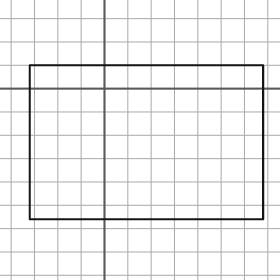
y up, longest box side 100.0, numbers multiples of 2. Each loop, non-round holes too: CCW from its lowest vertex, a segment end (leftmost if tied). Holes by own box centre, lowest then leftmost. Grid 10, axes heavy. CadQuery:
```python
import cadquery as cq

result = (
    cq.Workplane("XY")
    .moveTo(-32.0, -56.0)
    .lineTo(68.0, -56.0)
    .lineTo(68.0, 10.0)
    .lineTo(-32.0, 10.0)
    .close()
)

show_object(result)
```